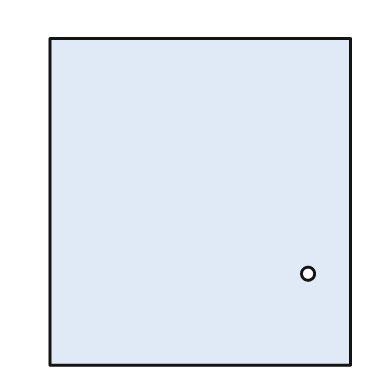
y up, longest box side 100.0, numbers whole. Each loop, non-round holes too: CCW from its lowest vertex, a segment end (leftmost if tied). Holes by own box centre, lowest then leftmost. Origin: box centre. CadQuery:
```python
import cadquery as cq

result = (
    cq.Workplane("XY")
    .moveTo(-46.0, -50.0)
    .lineTo(46.0, -50.0)
    .lineTo(46.0, 50.0)
    .lineTo(-46.0, 50.0)
    .close()
    .moveTo(33.0, -22.0)
    .circle(2.0)
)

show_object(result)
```